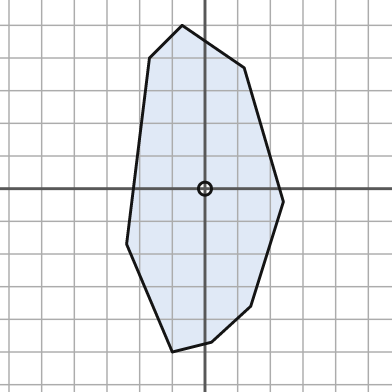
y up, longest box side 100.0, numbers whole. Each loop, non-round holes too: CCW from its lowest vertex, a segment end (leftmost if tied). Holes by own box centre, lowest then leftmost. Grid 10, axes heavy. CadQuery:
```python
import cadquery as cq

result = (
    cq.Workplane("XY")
    .moveTo(-10.0, -50.0)
    .lineTo(2.0, -47.0)
    .lineTo(14.0, -36.0)
    .lineTo(24.0, -4.0)
    .lineTo(12.0, 37.0)
    .lineTo(-7.0, 50.0)
    .lineTo(-17.0, 40.0)
    .lineTo(-24.0, -17.0)
    .close()
    .moveTo(0.0, 0.0)
    .circle(2.0)
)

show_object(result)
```